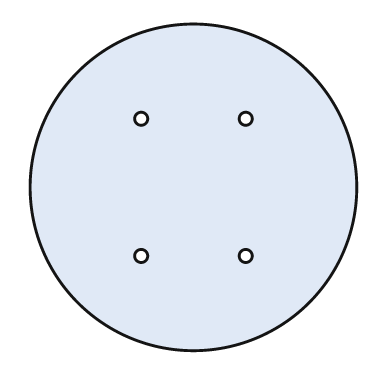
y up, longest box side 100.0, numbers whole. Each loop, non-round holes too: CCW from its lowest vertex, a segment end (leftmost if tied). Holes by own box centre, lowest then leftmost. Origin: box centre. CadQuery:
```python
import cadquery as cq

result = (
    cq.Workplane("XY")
    .moveTo(0.0, 0.0)
    .circle(50.0)
    .moveTo(-16.0, -21.0)
    .circle(2.0)
    .moveTo(16.0, -21.0)
    .circle(2.0)
    .moveTo(-16.0, 21.0)
    .circle(2.0)
    .moveTo(16.0, 21.0)
    .circle(2.0)
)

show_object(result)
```